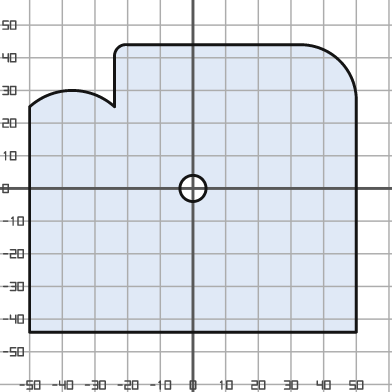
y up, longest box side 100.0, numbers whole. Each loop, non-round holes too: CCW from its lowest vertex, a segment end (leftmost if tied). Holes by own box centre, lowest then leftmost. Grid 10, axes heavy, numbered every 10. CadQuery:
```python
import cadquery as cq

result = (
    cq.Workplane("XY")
    .moveTo(-50.0, -44.0)
    .lineTo(50.0, -44.0)
    .lineTo(50.0, 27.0)
    .threePointArc((45.0, 39.0), (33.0, 44.0))
    .lineTo(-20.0, 44.0)
    .threePointArc((-23.0, 43.0), (-24.0, 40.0))
    .lineTo(-24.0, 25.0)
    .threePointArc((-37.0, 30.0), (-50.0, 25.0))
    .close()
    .moveTo(0.0, 0.0)
    .circle(4.0)
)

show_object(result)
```